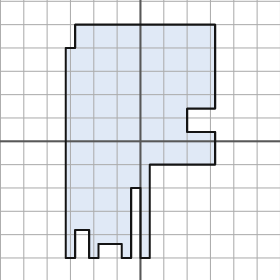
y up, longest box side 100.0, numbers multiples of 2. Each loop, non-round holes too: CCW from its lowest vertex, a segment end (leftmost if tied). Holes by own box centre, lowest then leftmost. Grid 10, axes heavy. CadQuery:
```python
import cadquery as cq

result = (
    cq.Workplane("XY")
    .moveTo(-32.0, -50.0)
    .lineTo(-28.0, -50.0)
    .lineTo(-28.0, -38.0)
    .lineTo(-22.0, -38.0)
    .lineTo(-22.0, -50.0)
    .lineTo(-18.0, -50.0)
    .lineTo(-18.0, -44.0)
    .lineTo(-8.0, -44.0)
    .lineTo(-8.0, -50.0)
    .lineTo(-4.0, -50.0)
    .lineTo(-4.0, -20.0)
    .lineTo(0.0, -20.0)
    .lineTo(0.0, -50.0)
    .lineTo(4.0, -50.0)
    .lineTo(4.0, -10.0)
    .lineTo(32.0, -10.0)
    .lineTo(32.0, 4.0)
    .lineTo(20.0, 4.0)
    .lineTo(20.0, 14.0)
    .lineTo(32.0, 14.0)
    .lineTo(32.0, 50.0)
    .lineTo(-28.0, 50.0)
    .lineTo(-28.0, 40.0)
    .lineTo(-32.0, 40.0)
    .close()
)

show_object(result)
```